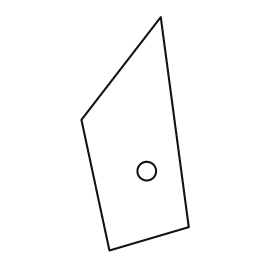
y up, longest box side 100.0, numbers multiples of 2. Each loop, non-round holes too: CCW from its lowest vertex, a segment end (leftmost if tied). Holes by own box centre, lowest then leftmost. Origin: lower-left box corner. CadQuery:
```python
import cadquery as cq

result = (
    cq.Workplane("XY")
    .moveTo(12.0, 0.0)
    .lineTo(46.0, 10.0)
    .lineTo(34.0, 100.0)
    .lineTo(0.0, 56.0)
    .close()
    .moveTo(28.0, 34.0)
    .circle(4.0)
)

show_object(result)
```